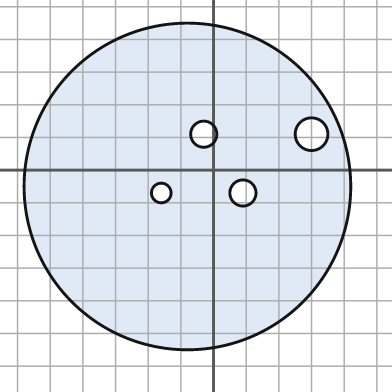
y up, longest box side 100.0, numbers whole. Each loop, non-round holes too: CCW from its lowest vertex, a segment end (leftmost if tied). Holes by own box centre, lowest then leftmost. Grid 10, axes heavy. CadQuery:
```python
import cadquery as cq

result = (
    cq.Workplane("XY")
    .moveTo(-8.0, -5.0)
    .circle(50.0)
    .moveTo(-16.0, -7.0)
    .circle(3.0)
    .moveTo(9.0, -7.0)
    .circle(4.0)
    .moveTo(-3.0, 11.0)
    .circle(4.0)
    .moveTo(30.0, 11.0)
    .circle(5.0)
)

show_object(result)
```